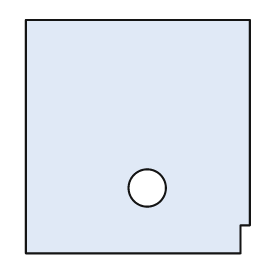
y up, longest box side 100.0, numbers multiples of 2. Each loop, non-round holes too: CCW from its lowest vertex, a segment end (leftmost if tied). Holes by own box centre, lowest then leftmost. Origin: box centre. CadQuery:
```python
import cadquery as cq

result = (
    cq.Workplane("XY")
    .moveTo(-48.0, -50.0)
    .lineTo(44.0, -50.0)
    .lineTo(44.0, -38.0)
    .lineTo(48.0, -38.0)
    .lineTo(48.0, 50.0)
    .lineTo(-48.0, 50.0)
    .close()
    .moveTo(4.0, -22.0)
    .circle(8.0)
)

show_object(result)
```